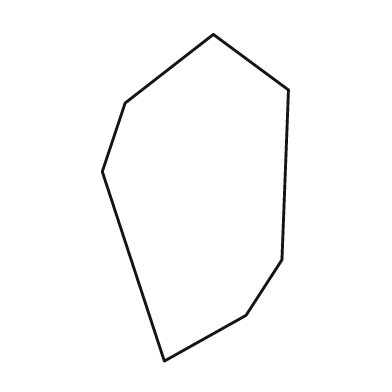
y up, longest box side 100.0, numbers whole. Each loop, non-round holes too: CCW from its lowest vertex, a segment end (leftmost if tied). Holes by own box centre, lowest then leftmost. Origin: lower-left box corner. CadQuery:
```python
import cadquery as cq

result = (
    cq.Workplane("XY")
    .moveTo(19.0, 0.0)
    .lineTo(44.0, 14.0)
    .lineTo(55.0, 31.0)
    .lineTo(57.0, 83.0)
    .lineTo(34.0, 100.0)
    .lineTo(7.0, 79.0)
    .lineTo(0.0, 58.0)
    .close()
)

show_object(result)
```